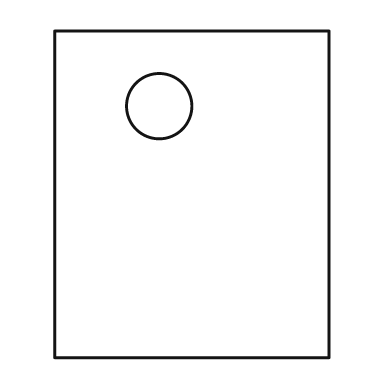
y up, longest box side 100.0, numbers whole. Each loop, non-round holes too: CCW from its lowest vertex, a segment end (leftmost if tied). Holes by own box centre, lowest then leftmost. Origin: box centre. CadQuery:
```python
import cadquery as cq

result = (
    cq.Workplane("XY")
    .moveTo(-42.0, -50.0)
    .lineTo(42.0, -50.0)
    .lineTo(42.0, 50.0)
    .lineTo(-42.0, 50.0)
    .close()
    .moveTo(-10.0, 27.0)
    .circle(10.0)
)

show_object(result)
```